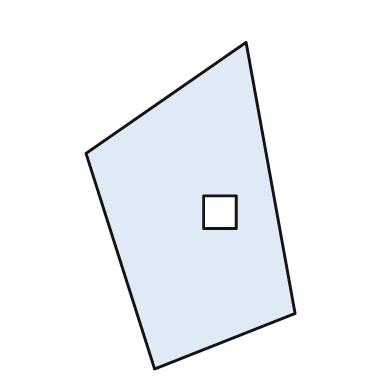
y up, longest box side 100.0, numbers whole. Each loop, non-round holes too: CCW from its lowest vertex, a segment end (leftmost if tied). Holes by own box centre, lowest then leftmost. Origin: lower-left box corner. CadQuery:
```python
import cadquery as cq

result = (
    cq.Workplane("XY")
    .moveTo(21.0, 0.0)
    .lineTo(64.0, 17.0)
    .lineTo(49.0, 100.0)
    .lineTo(0.0, 66.0)
    .close()
    .moveTo(36.0, 43.0)
    .lineTo(46.0, 43.0)
    .lineTo(46.0, 53.0)
    .lineTo(36.0, 53.0)
    .close()
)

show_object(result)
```